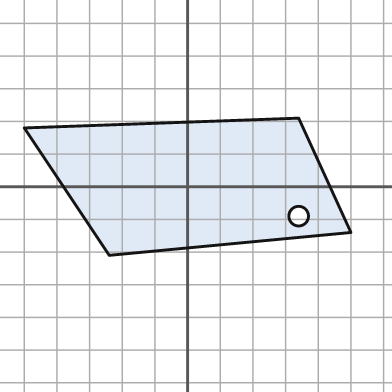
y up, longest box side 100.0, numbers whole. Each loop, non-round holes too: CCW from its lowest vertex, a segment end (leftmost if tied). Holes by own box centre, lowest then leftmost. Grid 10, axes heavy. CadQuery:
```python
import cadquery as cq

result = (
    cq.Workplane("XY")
    .moveTo(-24.0, -21.0)
    .lineTo(50.0, -14.0)
    .lineTo(34.0, 21.0)
    .lineTo(-50.0, 18.0)
    .close()
    .moveTo(34.0, -9.0)
    .circle(3.0)
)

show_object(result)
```